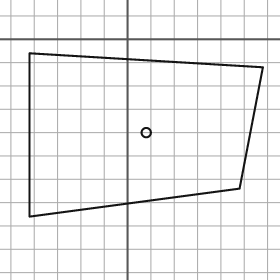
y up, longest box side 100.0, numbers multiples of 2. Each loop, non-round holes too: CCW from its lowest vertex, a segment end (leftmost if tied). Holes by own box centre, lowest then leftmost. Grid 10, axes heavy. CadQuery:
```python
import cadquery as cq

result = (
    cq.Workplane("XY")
    .moveTo(-42.0, -76.0)
    .lineTo(48.0, -64.0)
    .lineTo(58.0, -12.0)
    .lineTo(-42.0, -6.0)
    .close()
    .moveTo(8.0, -40.0)
    .circle(2.0)
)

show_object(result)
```